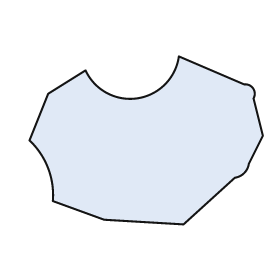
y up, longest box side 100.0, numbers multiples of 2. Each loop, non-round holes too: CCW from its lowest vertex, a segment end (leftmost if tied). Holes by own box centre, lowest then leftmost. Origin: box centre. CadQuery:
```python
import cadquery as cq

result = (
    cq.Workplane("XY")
    .moveTo(16.0, -36.0)
    .lineTo(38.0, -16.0)
    .threePointArc((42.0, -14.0), (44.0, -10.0))
    .lineTo(50.0, 2.0)
    .lineTo(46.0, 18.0)
    .threePointArc((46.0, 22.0), (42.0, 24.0))
    .lineTo(14.0, 36.0)
    .threePointArc((-4.0, 18.0), (-26.0, 30.0))
    .lineTo(-42.0, 20.0)
    .lineTo(-50.0, 0.0)
    .threePointArc((-42.0, -12.0), (-40.0, -26.0))
    .lineTo(-18.0, -34.0)
    .close()
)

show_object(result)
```